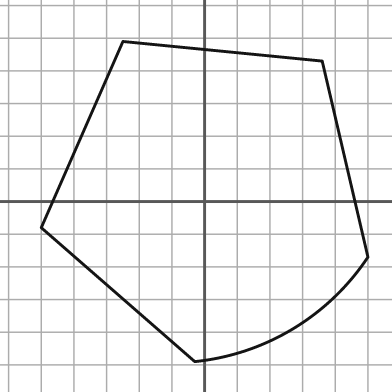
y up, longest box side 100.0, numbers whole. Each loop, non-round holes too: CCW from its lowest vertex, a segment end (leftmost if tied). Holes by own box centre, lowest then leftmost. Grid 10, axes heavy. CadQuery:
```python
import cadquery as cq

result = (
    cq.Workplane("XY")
    .moveTo(-3.0, -49.0)
    .threePointArc((27.0, -39.0), (50.0, -17.0))
    .lineTo(36.0, 43.0)
    .lineTo(-25.0, 49.0)
    .lineTo(-50.0, -8.0)
    .close()
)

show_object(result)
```